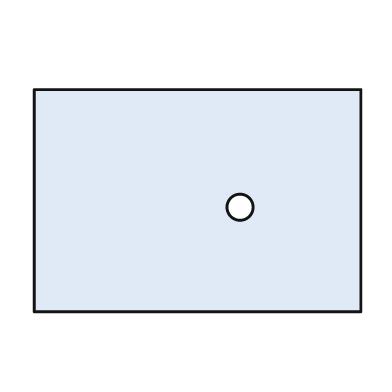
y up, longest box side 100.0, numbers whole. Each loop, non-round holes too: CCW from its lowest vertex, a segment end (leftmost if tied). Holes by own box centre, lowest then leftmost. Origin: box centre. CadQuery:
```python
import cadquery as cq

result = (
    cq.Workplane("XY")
    .moveTo(-50.0, -34.0)
    .lineTo(50.0, -34.0)
    .lineTo(50.0, 34.0)
    .lineTo(-50.0, 34.0)
    .close()
    .moveTo(13.0, -2.0)
    .circle(4.0)
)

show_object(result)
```